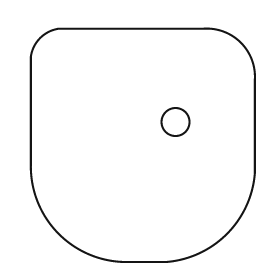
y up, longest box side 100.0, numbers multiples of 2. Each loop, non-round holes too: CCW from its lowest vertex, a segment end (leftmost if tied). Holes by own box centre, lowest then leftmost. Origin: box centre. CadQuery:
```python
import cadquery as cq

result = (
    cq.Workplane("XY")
    .moveTo(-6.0, -50.0)
    .lineTo(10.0, -50.0)
    .threePointArc((36.0, -38.0), (48.0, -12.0))
    .lineTo(48.0, 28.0)
    .threePointArc((42.0, 44.0), (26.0, 50.0))
    .lineTo(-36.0, 50.0)
    .threePointArc((-44.0, 46.0), (-48.0, 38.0))
    .lineTo(-48.0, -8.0)
    .threePointArc((-36.0, -38.0), (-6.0, -50.0))
    .close()
    .moveTo(14.0, 10.0)
    .circle(6.0)
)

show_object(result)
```